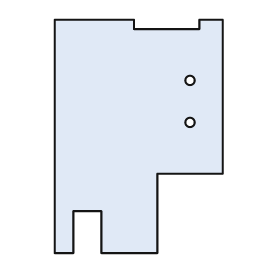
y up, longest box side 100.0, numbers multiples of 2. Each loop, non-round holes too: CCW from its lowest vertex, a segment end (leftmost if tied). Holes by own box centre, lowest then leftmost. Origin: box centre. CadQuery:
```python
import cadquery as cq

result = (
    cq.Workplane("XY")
    .moveTo(-36.0, -50.0)
    .lineTo(-28.0, -50.0)
    .lineTo(-28.0, -32.0)
    .lineTo(-16.0, -32.0)
    .lineTo(-16.0, -50.0)
    .lineTo(8.0, -50.0)
    .lineTo(8.0, -16.0)
    .lineTo(36.0, -16.0)
    .lineTo(36.0, 50.0)
    .lineTo(26.0, 50.0)
    .lineTo(26.0, 46.0)
    .lineTo(-2.0, 46.0)
    .lineTo(-2.0, 50.0)
    .lineTo(-36.0, 50.0)
    .close()
    .moveTo(22.0, 6.0)
    .circle(2.0)
    .moveTo(22.0, 24.0)
    .circle(2.0)
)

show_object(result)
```